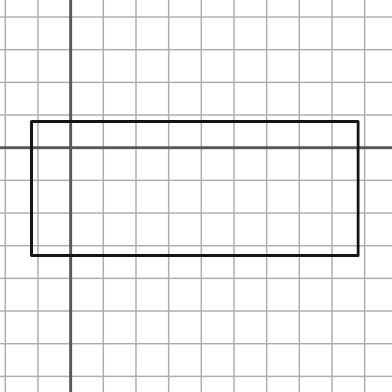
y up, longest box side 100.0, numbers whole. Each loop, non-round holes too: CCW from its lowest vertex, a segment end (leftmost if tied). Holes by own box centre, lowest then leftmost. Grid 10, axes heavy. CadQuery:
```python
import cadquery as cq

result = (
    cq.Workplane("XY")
    .moveTo(-12.0, -33.0)
    .lineTo(88.0, -33.0)
    .lineTo(88.0, 8.0)
    .lineTo(-12.0, 8.0)
    .close()
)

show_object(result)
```